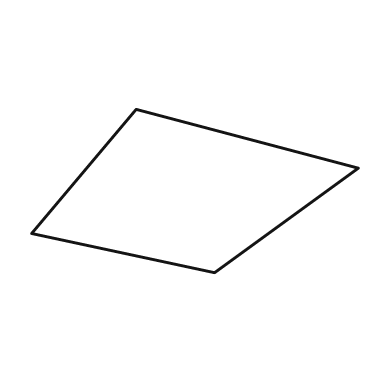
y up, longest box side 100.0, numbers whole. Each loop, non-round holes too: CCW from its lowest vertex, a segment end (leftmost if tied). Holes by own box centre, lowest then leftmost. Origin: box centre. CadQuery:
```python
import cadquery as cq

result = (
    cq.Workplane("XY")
    .moveTo(6.0, -25.0)
    .lineTo(50.0, 7.0)
    .lineTo(-18.0, 25.0)
    .lineTo(-50.0, -13.0)
    .close()
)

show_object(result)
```